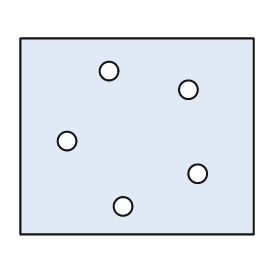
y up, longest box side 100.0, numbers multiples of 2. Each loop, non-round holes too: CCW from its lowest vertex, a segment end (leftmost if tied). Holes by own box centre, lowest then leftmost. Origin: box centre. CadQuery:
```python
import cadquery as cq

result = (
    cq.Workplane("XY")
    .moveTo(-50.0, -42.0)
    .lineTo(50.0, -42.0)
    .lineTo(50.0, 42.0)
    .lineTo(-50.0, 42.0)
    .close()
    .moveTo(-6.0, -30.0)
    .circle(4.0)
    .moveTo(26.0, -16.0)
    .circle(4.0)
    .moveTo(-30.0, -2.0)
    .circle(4.0)
    .moveTo(22.0, 20.0)
    .circle(4.0)
    .moveTo(-12.0, 28.0)
    .circle(4.0)
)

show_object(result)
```